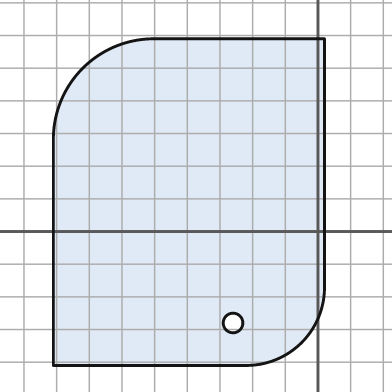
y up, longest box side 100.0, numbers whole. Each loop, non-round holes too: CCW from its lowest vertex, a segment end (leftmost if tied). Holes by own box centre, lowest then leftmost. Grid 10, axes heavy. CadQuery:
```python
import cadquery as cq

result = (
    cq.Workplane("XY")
    .moveTo(-81.0, -41.0)
    .lineTo(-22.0, -41.0)
    .threePointArc((-5.0, -34.0), (2.0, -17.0))
    .lineTo(2.0, 59.0)
    .lineTo(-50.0, 59.0)
    .threePointArc((-72.0, 50.0), (-81.0, 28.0))
    .close()
    .moveTo(-26.0, -28.0)
    .circle(3.0)
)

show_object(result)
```